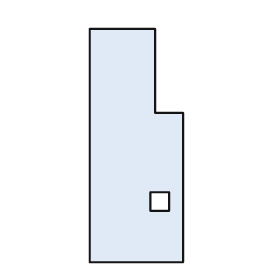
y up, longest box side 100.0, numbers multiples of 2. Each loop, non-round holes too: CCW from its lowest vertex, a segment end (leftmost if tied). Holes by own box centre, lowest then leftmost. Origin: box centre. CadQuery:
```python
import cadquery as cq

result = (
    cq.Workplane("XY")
    .moveTo(-20.0, -50.0)
    .lineTo(20.0, -50.0)
    .lineTo(20.0, 14.0)
    .lineTo(8.0, 14.0)
    .lineTo(8.0, 50.0)
    .lineTo(-20.0, 50.0)
    .close()
    .moveTo(6.0, -28.0)
    .lineTo(14.0, -28.0)
    .lineTo(14.0, -20.0)
    .lineTo(6.0, -20.0)
    .close()
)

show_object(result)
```